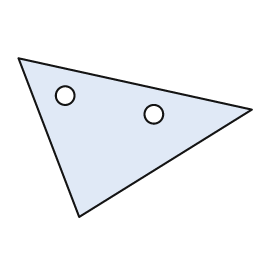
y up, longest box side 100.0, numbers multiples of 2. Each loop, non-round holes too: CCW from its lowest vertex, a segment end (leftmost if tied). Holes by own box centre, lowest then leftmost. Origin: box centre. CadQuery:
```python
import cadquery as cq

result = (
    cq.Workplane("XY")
    .moveTo(-24.0, -34.0)
    .lineTo(50.0, 12.0)
    .lineTo(-50.0, 34.0)
    .close()
    .moveTo(8.0, 10.0)
    .circle(4.0)
    .moveTo(-30.0, 18.0)
    .circle(4.0)
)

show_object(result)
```